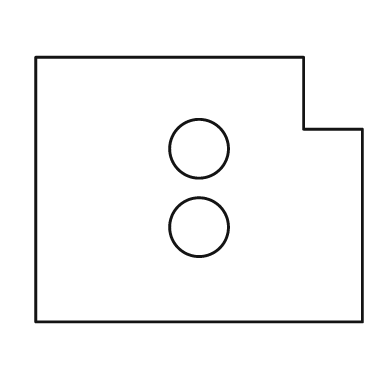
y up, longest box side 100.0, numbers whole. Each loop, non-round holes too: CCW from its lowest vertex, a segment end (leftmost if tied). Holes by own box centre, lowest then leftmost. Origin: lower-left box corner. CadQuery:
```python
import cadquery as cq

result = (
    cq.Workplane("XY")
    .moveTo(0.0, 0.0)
    .lineTo(100.0, 0.0)
    .lineTo(100.0, 59.0)
    .lineTo(82.0, 59.0)
    .lineTo(82.0, 81.0)
    .lineTo(0.0, 81.0)
    .close()
    .moveTo(50.0, 29.0)
    .circle(9.0)
    .moveTo(50.0, 53.0)
    .circle(9.0)
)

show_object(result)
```